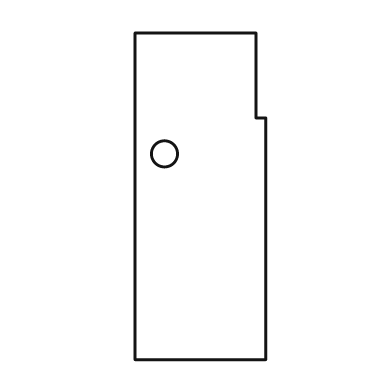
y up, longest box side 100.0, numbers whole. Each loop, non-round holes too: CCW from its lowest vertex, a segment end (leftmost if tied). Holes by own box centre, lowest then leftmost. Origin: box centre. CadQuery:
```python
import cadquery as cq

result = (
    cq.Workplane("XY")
    .moveTo(-20.0, -50.0)
    .lineTo(20.0, -50.0)
    .lineTo(20.0, 24.0)
    .lineTo(17.0, 24.0)
    .lineTo(17.0, 50.0)
    .lineTo(-20.0, 50.0)
    .close()
    .moveTo(-11.0, 13.0)
    .circle(4.0)
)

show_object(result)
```